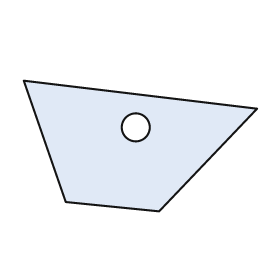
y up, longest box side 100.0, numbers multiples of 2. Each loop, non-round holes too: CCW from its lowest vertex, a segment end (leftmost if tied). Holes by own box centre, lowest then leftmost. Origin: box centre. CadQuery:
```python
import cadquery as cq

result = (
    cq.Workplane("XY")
    .moveTo(8.0, -28.0)
    .lineTo(50.0, 16.0)
    .lineTo(-50.0, 28.0)
    .lineTo(-32.0, -24.0)
    .close()
    .moveTo(-2.0, 8.0)
    .circle(6.0)
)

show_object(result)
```